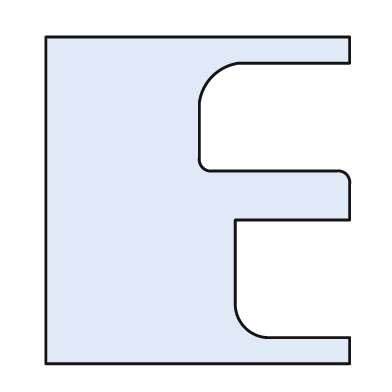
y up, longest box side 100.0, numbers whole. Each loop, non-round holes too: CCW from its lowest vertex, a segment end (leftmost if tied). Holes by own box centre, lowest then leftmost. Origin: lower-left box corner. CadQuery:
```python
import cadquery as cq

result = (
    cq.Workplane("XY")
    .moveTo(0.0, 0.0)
    .lineTo(93.0, 0.0)
    .lineTo(93.0, 8.0)
    .lineTo(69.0, 8.0)
    .threePointArc((61.0, 11.0), (58.0, 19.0))
    .lineTo(58.0, 44.0)
    .lineTo(93.0, 44.0)
    .lineTo(93.0, 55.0)
    .threePointArc((92.0, 58.0), (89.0, 59.0))
    .lineTo(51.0, 59.0)
    .threePointArc((48.0, 60.0), (47.0, 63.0))
    .lineTo(47.0, 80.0)
    .threePointArc((51.0, 88.0), (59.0, 92.0))
    .lineTo(93.0, 92.0)
    .lineTo(93.0, 100.0)
    .lineTo(0.0, 100.0)
    .close()
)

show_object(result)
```